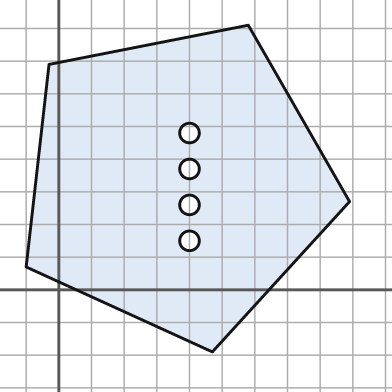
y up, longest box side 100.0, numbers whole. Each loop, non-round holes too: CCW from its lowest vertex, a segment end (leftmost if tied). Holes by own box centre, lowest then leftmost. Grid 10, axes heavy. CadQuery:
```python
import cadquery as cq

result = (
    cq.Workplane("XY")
    .moveTo(47.0, -19.0)
    .lineTo(89.0, 27.0)
    .lineTo(58.0, 81.0)
    .lineTo(-3.0, 69.0)
    .lineTo(-10.0, 7.0)
    .close()
    .moveTo(40.0, 15.0)
    .circle(3.0)
    .moveTo(40.0, 26.0)
    .circle(3.0)
    .moveTo(40.0, 37.0)
    .circle(3.0)
    .moveTo(40.0, 48.0)
    .circle(3.0)
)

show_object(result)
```